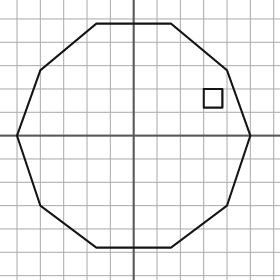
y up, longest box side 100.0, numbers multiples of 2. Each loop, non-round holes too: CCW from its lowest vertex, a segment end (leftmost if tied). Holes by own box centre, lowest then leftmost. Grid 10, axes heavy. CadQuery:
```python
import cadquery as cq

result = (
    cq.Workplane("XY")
    .moveTo(-16.0, -48.0)
    .lineTo(16.0, -48.0)
    .lineTo(40.0, -30.0)
    .lineTo(50.0, 0.0)
    .lineTo(40.0, 28.0)
    .lineTo(16.0, 48.0)
    .lineTo(-16.0, 48.0)
    .lineTo(-40.0, 28.0)
    .lineTo(-50.0, 0.0)
    .lineTo(-40.0, -30.0)
    .close()
    .moveTo(30.0, 12.0)
    .lineTo(38.0, 12.0)
    .lineTo(38.0, 20.0)
    .lineTo(30.0, 20.0)
    .close()
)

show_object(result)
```